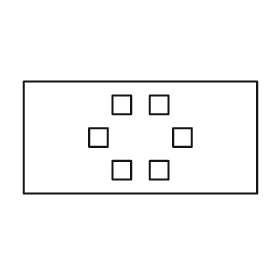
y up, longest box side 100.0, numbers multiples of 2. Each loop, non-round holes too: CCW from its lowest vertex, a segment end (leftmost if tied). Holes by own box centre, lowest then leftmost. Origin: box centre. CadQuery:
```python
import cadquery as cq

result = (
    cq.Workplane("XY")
    .moveTo(-50.0, -24.0)
    .lineTo(50.0, -24.0)
    .lineTo(50.0, 24.0)
    .lineTo(-50.0, 24.0)
    .close()
    .moveTo(-12.0, -18.0)
    .lineTo(-4.0, -18.0)
    .lineTo(-4.0, -10.0)
    .lineTo(-12.0, -10.0)
    .close()
    .moveTo(4.0, -18.0)
    .lineTo(12.0, -18.0)
    .lineTo(12.0, -10.0)
    .lineTo(4.0, -10.0)
    .close()
    .moveTo(-22.0, -4.0)
    .lineTo(-14.0, -4.0)
    .lineTo(-14.0, 4.0)
    .lineTo(-22.0, 4.0)
    .close()
    .moveTo(14.0, -4.0)
    .lineTo(22.0, -4.0)
    .lineTo(22.0, 4.0)
    .lineTo(14.0, 4.0)
    .close()
    .moveTo(-12.0, 10.0)
    .lineTo(-4.0, 10.0)
    .lineTo(-4.0, 18.0)
    .lineTo(-12.0, 18.0)
    .close()
    .moveTo(4.0, 10.0)
    .lineTo(12.0, 10.0)
    .lineTo(12.0, 18.0)
    .lineTo(4.0, 18.0)
    .close()
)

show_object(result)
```